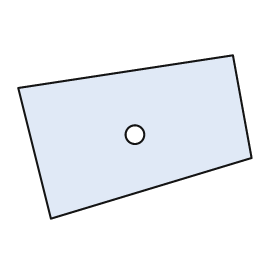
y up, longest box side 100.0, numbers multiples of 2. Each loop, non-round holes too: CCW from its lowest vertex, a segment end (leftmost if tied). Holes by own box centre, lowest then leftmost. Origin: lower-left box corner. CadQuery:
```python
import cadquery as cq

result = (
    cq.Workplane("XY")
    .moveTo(14.0, 0.0)
    .lineTo(100.0, 26.0)
    .lineTo(92.0, 70.0)
    .lineTo(0.0, 56.0)
    .close()
    .moveTo(50.0, 36.0)
    .circle(4.0)
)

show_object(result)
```